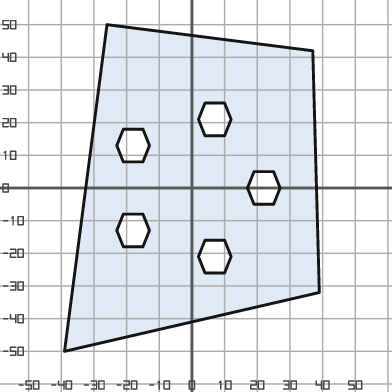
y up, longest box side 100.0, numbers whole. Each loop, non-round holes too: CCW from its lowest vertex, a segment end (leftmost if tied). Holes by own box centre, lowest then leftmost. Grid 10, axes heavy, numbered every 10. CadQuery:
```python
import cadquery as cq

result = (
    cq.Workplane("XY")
    .moveTo(-39.0, -50.0)
    .lineTo(39.0, -32.0)
    .lineTo(37.0, 42.0)
    .lineTo(-26.0, 50.0)
    .close()
    .moveTo(4.0, -26.0)
    .lineTo(10.0, -26.0)
    .lineTo(12.0, -21.0)
    .lineTo(10.0, -16.0)
    .lineTo(4.0, -16.0)
    .lineTo(2.0, -21.0)
    .close()
    .moveTo(-21.0, -18.0)
    .lineTo(-15.0, -18.0)
    .lineTo(-13.0, -13.0)
    .lineTo(-15.0, -8.0)
    .lineTo(-21.0, -8.0)
    .lineTo(-23.0, -13.0)
    .close()
    .moveTo(19.0, -5.0)
    .lineTo(25.0, -5.0)
    .lineTo(27.0, 0.0)
    .lineTo(25.0, 5.0)
    .lineTo(19.0, 5.0)
    .lineTo(17.0, 0.0)
    .close()
    .moveTo(-21.0, 8.0)
    .lineTo(-15.0, 8.0)
    .lineTo(-13.0, 13.0)
    .lineTo(-15.0, 18.0)
    .lineTo(-21.0, 18.0)
    .lineTo(-23.0, 13.0)
    .close()
    .moveTo(4.0, 16.0)
    .lineTo(10.0, 16.0)
    .lineTo(12.0, 21.0)
    .lineTo(10.0, 26.0)
    .lineTo(4.0, 26.0)
    .lineTo(2.0, 21.0)
    .close()
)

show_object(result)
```